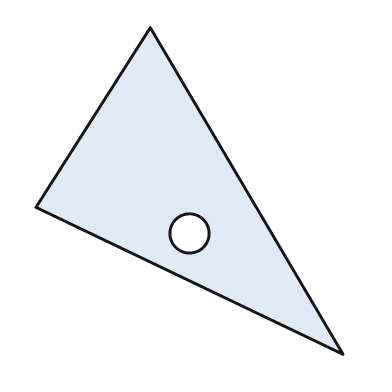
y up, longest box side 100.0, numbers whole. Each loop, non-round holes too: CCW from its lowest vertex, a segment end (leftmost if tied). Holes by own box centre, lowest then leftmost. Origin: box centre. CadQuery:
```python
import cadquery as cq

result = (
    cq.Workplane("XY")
    .moveTo(47.0, -50.0)
    .lineTo(-12.0, 50.0)
    .lineTo(-47.0, -5.0)
    .close()
    .moveTo(0.0, -13.0)
    .circle(6.0)
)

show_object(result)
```